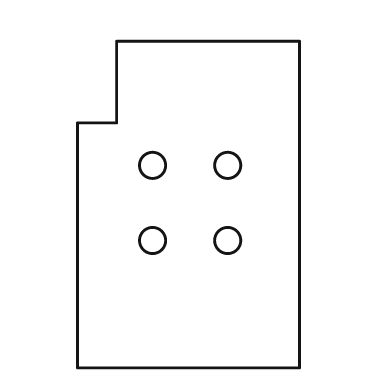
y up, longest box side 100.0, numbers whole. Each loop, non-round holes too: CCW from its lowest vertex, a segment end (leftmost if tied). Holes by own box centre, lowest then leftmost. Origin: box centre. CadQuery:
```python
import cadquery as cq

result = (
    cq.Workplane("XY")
    .moveTo(-34.0, -50.0)
    .lineTo(34.0, -50.0)
    .lineTo(34.0, 50.0)
    .lineTo(-22.0, 50.0)
    .lineTo(-22.0, 25.0)
    .lineTo(-34.0, 25.0)
    .close()
    .moveTo(-11.0, -11.0)
    .circle(4.0)
    .moveTo(12.0, -11.0)
    .circle(4.0)
    .moveTo(-11.0, 12.0)
    .circle(4.0)
    .moveTo(12.0, 12.0)
    .circle(4.0)
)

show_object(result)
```